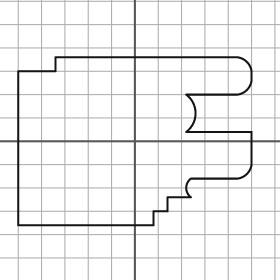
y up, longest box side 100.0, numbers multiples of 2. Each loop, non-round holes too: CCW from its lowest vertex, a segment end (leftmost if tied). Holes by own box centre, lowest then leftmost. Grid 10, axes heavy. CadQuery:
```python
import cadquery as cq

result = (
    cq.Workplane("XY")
    .moveTo(-50.0, -36.0)
    .lineTo(8.0, -36.0)
    .lineTo(8.0, -30.0)
    .lineTo(14.0, -30.0)
    .lineTo(14.0, -24.0)
    .lineTo(24.0, -24.0)
    .threePointArc((22.0, -20.0), (24.0, -16.0))
    .lineTo(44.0, -16.0)
    .threePointArc((48.0, -14.0), (50.0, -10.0))
    .lineTo(50.0, 4.0)
    .lineTo(22.0, 4.0)
    .threePointArc((26.0, 12.0), (22.0, 20.0))
    .lineTo(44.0, 20.0)
    .threePointArc((48.0, 22.0), (50.0, 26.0))
    .lineTo(50.0, 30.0)
    .threePointArc((48.0, 34.0), (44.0, 36.0))
    .lineTo(-34.0, 36.0)
    .lineTo(-34.0, 30.0)
    .lineTo(-50.0, 30.0)
    .close()
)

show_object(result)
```